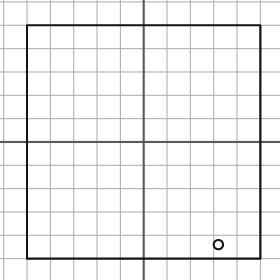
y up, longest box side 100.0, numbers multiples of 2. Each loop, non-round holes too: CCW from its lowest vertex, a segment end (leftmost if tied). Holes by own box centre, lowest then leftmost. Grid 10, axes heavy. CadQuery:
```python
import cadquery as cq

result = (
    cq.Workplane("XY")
    .moveTo(-50.0, -50.0)
    .lineTo(50.0, -50.0)
    .lineTo(50.0, 50.0)
    .lineTo(-50.0, 50.0)
    .close()
    .moveTo(32.0, -44.0)
    .circle(2.0)
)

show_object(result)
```